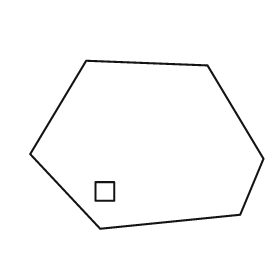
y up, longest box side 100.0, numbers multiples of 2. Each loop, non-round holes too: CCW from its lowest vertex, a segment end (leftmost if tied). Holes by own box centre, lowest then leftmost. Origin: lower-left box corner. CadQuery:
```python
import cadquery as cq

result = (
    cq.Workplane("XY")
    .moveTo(30.0, 0.0)
    .lineTo(90.0, 6.0)
    .lineTo(100.0, 30.0)
    .lineTo(76.0, 70.0)
    .lineTo(24.0, 72.0)
    .lineTo(0.0, 32.0)
    .close()
    .moveTo(28.0, 12.0)
    .lineTo(36.0, 12.0)
    .lineTo(36.0, 20.0)
    .lineTo(28.0, 20.0)
    .close()
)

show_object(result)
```